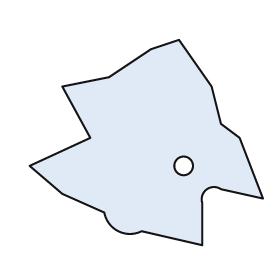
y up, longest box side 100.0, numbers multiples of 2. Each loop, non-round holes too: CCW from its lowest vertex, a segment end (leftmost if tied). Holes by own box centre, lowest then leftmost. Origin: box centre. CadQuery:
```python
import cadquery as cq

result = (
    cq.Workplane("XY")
    .moveTo(24.0, -44.0)
    .lineTo(24.0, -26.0)
    .threePointArc((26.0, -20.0), (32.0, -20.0))
    .lineTo(50.0, -24.0)
    .lineTo(40.0, 2.0)
    .lineTo(32.0, 8.0)
    .lineTo(28.0, 24.0)
    .lineTo(14.0, 44.0)
    .lineTo(2.0, 40.0)
    .lineTo(-16.0, 28.0)
    .lineTo(-36.0, 24.0)
    .lineTo(-24.0, 2.0)
    .lineTo(-50.0, -10.0)
    .lineTo(-36.0, -22.0)
    .lineTo(-18.0, -30.0)
    .threePointArc((-12.0, -38.0), (-2.0, -38.0))
    .close()
    .moveTo(16.0, -10.0)
    .circle(4.0)
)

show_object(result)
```